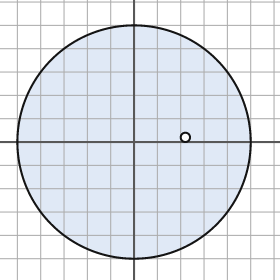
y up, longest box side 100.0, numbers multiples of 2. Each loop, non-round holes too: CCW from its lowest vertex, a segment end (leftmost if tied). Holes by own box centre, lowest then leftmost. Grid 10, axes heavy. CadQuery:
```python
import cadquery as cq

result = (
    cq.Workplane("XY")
    .moveTo(0.0, 0.0)
    .circle(50.0)
    .moveTo(22.0, 2.0)
    .circle(2.0)
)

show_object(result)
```